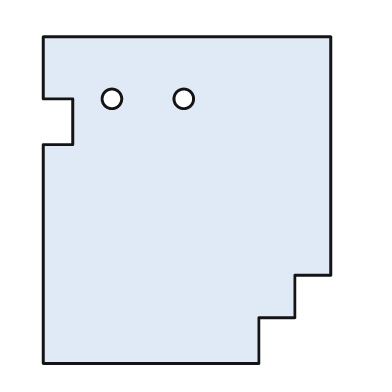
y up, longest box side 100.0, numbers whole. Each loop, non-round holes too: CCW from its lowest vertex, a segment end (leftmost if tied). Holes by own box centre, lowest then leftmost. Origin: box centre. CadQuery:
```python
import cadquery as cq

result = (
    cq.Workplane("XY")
    .moveTo(-44.0, -50.0)
    .lineTo(22.0, -50.0)
    .lineTo(22.0, -36.0)
    .lineTo(33.0, -36.0)
    .lineTo(33.0, -23.0)
    .lineTo(44.0, -23.0)
    .lineTo(44.0, 50.0)
    .lineTo(-44.0, 50.0)
    .lineTo(-44.0, 31.0)
    .lineTo(-35.0, 31.0)
    .lineTo(-35.0, 17.0)
    .lineTo(-44.0, 17.0)
    .close()
    .moveTo(-23.0, 31.0)
    .circle(3.0)
    .moveTo(-1.0, 31.0)
    .circle(3.0)
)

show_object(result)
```